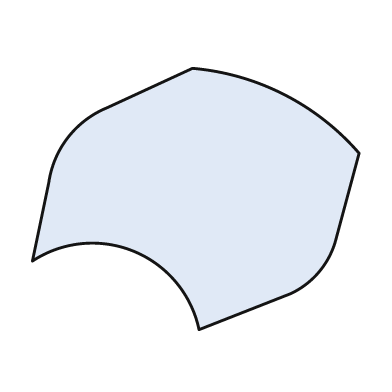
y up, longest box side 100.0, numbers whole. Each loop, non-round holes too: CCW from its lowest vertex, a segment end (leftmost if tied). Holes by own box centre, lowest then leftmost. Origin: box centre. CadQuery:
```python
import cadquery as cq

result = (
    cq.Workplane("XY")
    .moveTo(1.0, -40.0)
    .lineTo(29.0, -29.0)
    .threePointArc((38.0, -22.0), (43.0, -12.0))
    .lineTo(50.0, 14.0)
    .threePointArc((27.0, 32.0), (-1.0, 40.0))
    .lineTo(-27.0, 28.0)
    .threePointArc((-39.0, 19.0), (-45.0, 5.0))
    .lineTo(-50.0, -19.0)
    .threePointArc((-19.0, -16.0), (1.0, -40.0))
    .close()
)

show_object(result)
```